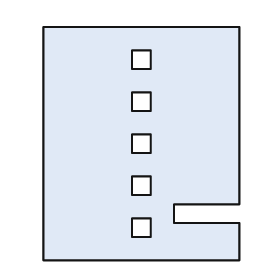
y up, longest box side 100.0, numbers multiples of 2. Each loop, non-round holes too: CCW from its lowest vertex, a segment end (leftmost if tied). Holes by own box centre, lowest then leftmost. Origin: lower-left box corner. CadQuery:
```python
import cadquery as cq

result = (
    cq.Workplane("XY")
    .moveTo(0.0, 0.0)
    .lineTo(84.0, 0.0)
    .lineTo(84.0, 16.0)
    .lineTo(56.0, 16.0)
    .lineTo(56.0, 24.0)
    .lineTo(84.0, 24.0)
    .lineTo(84.0, 100.0)
    .lineTo(0.0, 100.0)
    .close()
    .moveTo(38.0, 10.0)
    .lineTo(46.0, 10.0)
    .lineTo(46.0, 18.0)
    .lineTo(38.0, 18.0)
    .close()
    .moveTo(38.0, 28.0)
    .lineTo(46.0, 28.0)
    .lineTo(46.0, 36.0)
    .lineTo(38.0, 36.0)
    .close()
    .moveTo(38.0, 46.0)
    .lineTo(46.0, 46.0)
    .lineTo(46.0, 54.0)
    .lineTo(38.0, 54.0)
    .close()
    .moveTo(38.0, 64.0)
    .lineTo(46.0, 64.0)
    .lineTo(46.0, 72.0)
    .lineTo(38.0, 72.0)
    .close()
    .moveTo(38.0, 82.0)
    .lineTo(46.0, 82.0)
    .lineTo(46.0, 90.0)
    .lineTo(38.0, 90.0)
    .close()
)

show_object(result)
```